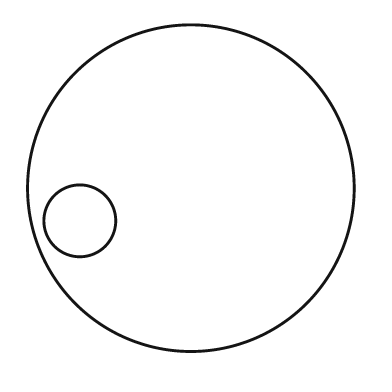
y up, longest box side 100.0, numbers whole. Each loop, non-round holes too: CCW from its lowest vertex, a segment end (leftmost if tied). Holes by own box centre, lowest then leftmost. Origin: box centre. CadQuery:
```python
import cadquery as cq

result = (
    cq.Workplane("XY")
    .moveTo(0.0, 0.0)
    .circle(50.0)
    .moveTo(-34.0, -10.0)
    .circle(11.0)
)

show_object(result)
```